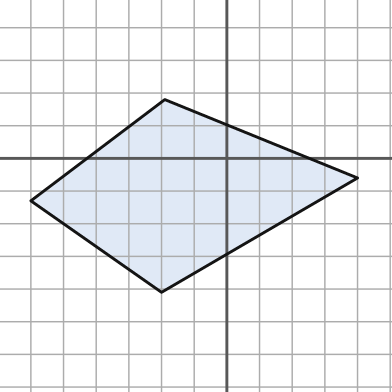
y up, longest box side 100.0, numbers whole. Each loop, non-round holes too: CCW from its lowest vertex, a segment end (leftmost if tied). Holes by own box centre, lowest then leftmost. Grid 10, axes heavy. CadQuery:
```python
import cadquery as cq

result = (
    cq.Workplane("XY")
    .moveTo(-20.0, -41.0)
    .lineTo(40.0, -6.0)
    .lineTo(-19.0, 18.0)
    .lineTo(-60.0, -13.0)
    .close()
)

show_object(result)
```